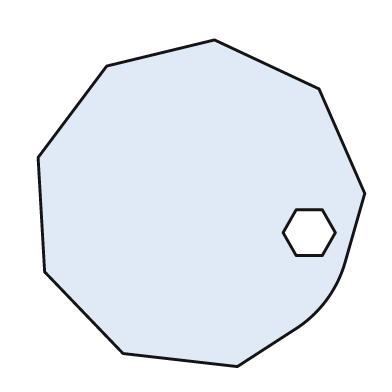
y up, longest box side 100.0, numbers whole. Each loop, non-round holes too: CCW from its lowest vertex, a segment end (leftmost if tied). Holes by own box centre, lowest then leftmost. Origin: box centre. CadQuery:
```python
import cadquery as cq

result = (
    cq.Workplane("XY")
    .moveTo(11.0, -50.0)
    .lineTo(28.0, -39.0)
    .threePointArc((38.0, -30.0), (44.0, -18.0))
    .lineTo(50.0, 3.0)
    .lineTo(36.0, 35.0)
    .lineTo(4.0, 50.0)
    .lineTo(-29.0, 42.0)
    .lineTo(-50.0, 14.0)
    .lineTo(-48.0, -21.0)
    .lineTo(-24.0, -46.0)
    .close()
    .moveTo(29.0, -16.0)
    .lineTo(37.0, -16.0)
    .lineTo(41.0, -9.0)
    .lineTo(37.0, -2.0)
    .lineTo(29.0, -2.0)
    .lineTo(25.0, -9.0)
    .close()
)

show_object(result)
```